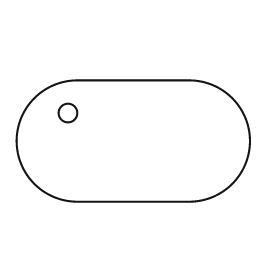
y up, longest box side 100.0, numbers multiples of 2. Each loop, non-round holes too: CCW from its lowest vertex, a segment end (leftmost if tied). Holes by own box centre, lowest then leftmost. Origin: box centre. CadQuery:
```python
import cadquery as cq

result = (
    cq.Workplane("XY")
    .moveTo(-24.0, -26.0)
    .lineTo(24.0, -26.0)
    .threePointArc((50.0, 0.0), (24.0, 26.0))
    .lineTo(-24.0, 26.0)
    .threePointArc((-50.0, 0.0), (-24.0, -26.0))
    .close()
    .moveTo(-28.0, 12.0)
    .circle(4.0)
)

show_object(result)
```